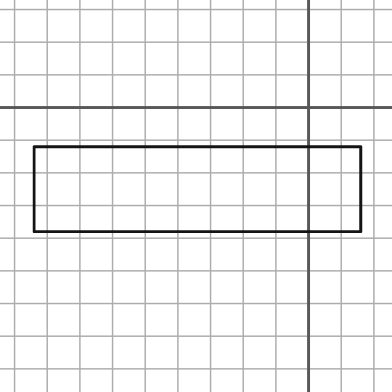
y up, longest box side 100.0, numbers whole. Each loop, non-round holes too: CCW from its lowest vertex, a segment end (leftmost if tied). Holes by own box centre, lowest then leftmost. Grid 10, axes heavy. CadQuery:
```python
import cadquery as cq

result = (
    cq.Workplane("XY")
    .moveTo(-84.0, -38.0)
    .lineTo(16.0, -38.0)
    .lineTo(16.0, -12.0)
    .lineTo(-84.0, -12.0)
    .close()
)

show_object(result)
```